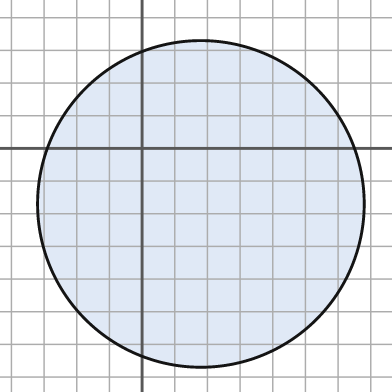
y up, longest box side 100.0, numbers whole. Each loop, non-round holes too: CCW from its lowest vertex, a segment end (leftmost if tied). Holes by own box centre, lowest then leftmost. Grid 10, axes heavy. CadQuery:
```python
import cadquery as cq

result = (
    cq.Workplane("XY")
    .moveTo(18.0, -17.0)
    .circle(50.0)
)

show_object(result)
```